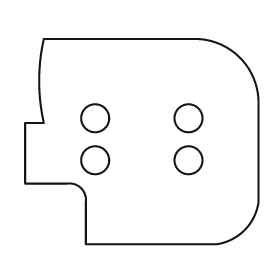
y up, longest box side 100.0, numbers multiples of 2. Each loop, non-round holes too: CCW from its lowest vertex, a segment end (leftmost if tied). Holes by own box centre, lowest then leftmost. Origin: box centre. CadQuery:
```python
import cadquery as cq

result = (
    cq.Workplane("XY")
    .moveTo(-24.0, -44.0)
    .lineTo(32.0, -44.0)
    .threePointArc((44.0, -38.0), (50.0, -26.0))
    .lineTo(50.0, 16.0)
    .threePointArc((42.0, 36.0), (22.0, 44.0))
    .lineTo(-42.0, 44.0)
    .threePointArc((-44.0, 26.0), (-42.0, 8.0))
    .lineTo(-50.0, 8.0)
    .lineTo(-50.0, -18.0)
    .lineTo(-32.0, -18.0)
    .threePointArc((-26.0, -20.0), (-24.0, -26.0))
    .close()
    .moveTo(-20.0, -8.0)
    .circle(6.0)
    .moveTo(20.0, -8.0)
    .circle(6.0)
    .moveTo(-20.0, 10.0)
    .circle(6.0)
    .moveTo(20.0, 10.0)
    .circle(6.0)
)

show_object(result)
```